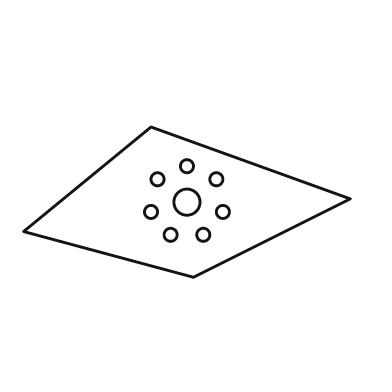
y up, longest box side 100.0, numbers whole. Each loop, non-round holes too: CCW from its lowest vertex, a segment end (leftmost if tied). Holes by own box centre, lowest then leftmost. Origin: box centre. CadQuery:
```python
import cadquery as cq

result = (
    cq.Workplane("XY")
    .moveTo(2.0, -23.0)
    .lineTo(50.0, 1.0)
    .lineTo(-11.0, 23.0)
    .lineTo(-50.0, -9.0)
    .close()
    .moveTo(-5.0, -10.0)
    .circle(2.0)
    .moveTo(5.0, -10.0)
    .circle(2.0)
    .moveTo(-11.0, -3.0)
    .circle(2.0)
    .moveTo(11.0, -3.0)
    .circle(2.0)
    .moveTo(0.0, 0.0)
    .circle(4.0)
    .moveTo(-9.0, 7.0)
    .circle(2.0)
    .moveTo(9.0, 7.0)
    .circle(2.0)
    .moveTo(0.0, 11.0)
    .circle(2.0)
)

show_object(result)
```